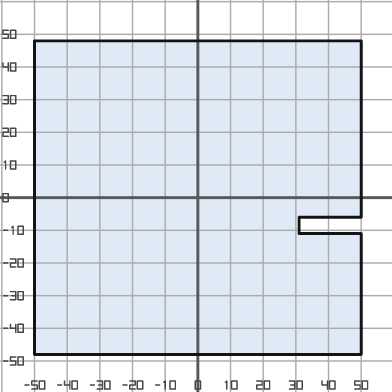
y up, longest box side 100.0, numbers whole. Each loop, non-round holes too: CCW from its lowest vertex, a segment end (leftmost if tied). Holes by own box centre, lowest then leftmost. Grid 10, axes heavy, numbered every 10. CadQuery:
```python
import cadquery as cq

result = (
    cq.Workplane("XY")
    .moveTo(-50.0, -48.0)
    .lineTo(50.0, -48.0)
    .lineTo(50.0, -11.0)
    .lineTo(31.0, -11.0)
    .lineTo(31.0, -6.0)
    .lineTo(50.0, -6.0)
    .lineTo(50.0, 48.0)
    .lineTo(-50.0, 48.0)
    .close()
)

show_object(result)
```